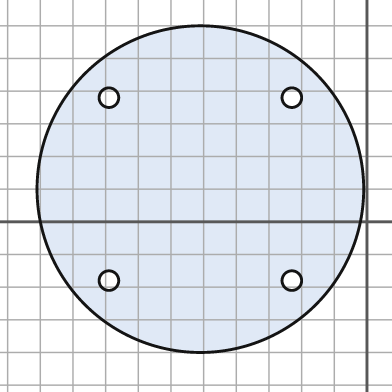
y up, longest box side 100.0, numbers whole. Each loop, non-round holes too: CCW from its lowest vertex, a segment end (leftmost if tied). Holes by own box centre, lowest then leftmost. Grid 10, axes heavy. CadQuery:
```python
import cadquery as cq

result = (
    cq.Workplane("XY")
    .moveTo(-51.0, 10.0)
    .circle(50.0)
    .moveTo(-79.0, -18.0)
    .circle(3.0)
    .moveTo(-23.0, -18.0)
    .circle(3.0)
    .moveTo(-79.0, 38.0)
    .circle(3.0)
    .moveTo(-23.0, 38.0)
    .circle(3.0)
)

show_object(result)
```